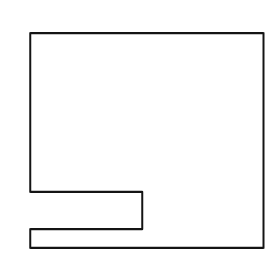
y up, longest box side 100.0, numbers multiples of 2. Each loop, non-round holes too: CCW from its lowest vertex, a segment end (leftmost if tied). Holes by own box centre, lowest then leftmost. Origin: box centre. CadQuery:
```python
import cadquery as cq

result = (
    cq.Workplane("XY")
    .moveTo(-50.0, -46.0)
    .lineTo(50.0, -46.0)
    .lineTo(50.0, 46.0)
    .lineTo(-50.0, 46.0)
    .lineTo(-50.0, -22.0)
    .lineTo(-2.0, -22.0)
    .lineTo(-2.0, -38.0)
    .lineTo(-50.0, -38.0)
    .close()
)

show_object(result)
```